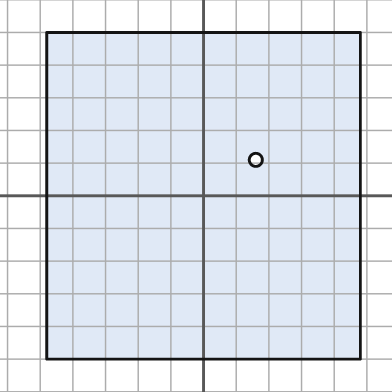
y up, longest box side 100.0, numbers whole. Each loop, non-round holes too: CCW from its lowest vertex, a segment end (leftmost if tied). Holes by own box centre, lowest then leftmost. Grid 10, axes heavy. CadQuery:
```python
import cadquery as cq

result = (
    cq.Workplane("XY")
    .moveTo(-48.0, -50.0)
    .lineTo(48.0, -50.0)
    .lineTo(48.0, 50.0)
    .lineTo(-48.0, 50.0)
    .close()
    .moveTo(16.0, 11.0)
    .circle(2.0)
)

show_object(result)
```